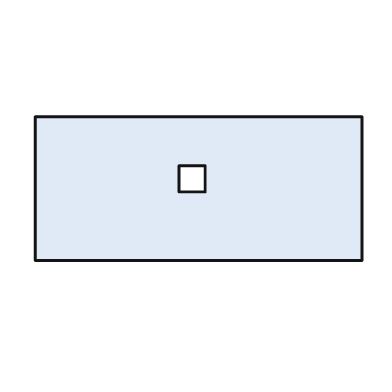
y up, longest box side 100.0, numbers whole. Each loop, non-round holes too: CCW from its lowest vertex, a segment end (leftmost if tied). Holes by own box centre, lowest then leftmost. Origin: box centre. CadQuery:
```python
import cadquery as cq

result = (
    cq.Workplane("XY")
    .moveTo(-50.0, -22.0)
    .lineTo(50.0, -22.0)
    .lineTo(50.0, 22.0)
    .lineTo(-50.0, 22.0)
    .close()
    .moveTo(-6.0, -1.0)
    .lineTo(2.0, -1.0)
    .lineTo(2.0, 7.0)
    .lineTo(-6.0, 7.0)
    .close()
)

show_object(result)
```